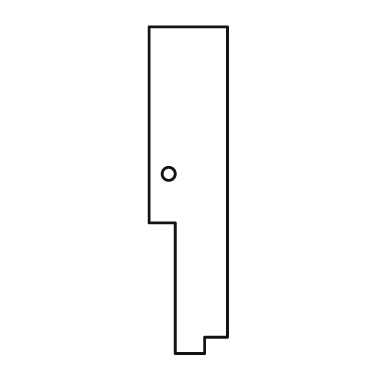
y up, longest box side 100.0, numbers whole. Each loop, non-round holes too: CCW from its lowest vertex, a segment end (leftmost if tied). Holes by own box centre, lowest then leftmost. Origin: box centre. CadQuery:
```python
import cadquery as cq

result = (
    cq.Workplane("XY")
    .moveTo(-4.0, -50.0)
    .lineTo(5.0, -50.0)
    .lineTo(5.0, -45.0)
    .lineTo(12.0, -45.0)
    .lineTo(12.0, 50.0)
    .lineTo(-12.0, 50.0)
    .lineTo(-12.0, -10.0)
    .lineTo(-4.0, -10.0)
    .close()
    .moveTo(-6.0, 5.0)
    .circle(2.0)
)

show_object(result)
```